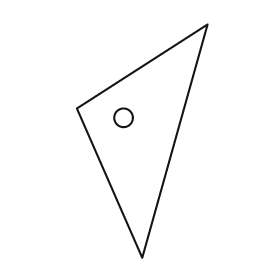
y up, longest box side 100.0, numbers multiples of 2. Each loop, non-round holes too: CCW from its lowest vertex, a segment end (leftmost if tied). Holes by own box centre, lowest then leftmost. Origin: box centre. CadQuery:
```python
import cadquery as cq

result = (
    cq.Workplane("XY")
    .moveTo(0.0, -50.0)
    .lineTo(28.0, 50.0)
    .lineTo(-28.0, 14.0)
    .close()
    .moveTo(-8.0, 10.0)
    .circle(4.0)
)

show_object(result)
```